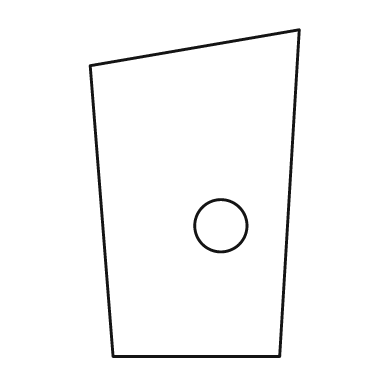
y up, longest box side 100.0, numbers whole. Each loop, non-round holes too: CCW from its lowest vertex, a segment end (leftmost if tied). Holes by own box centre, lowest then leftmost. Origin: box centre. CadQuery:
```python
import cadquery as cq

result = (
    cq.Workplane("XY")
    .moveTo(-25.0, -50.0)
    .lineTo(26.0, -50.0)
    .lineTo(32.0, 50.0)
    .lineTo(-32.0, 39.0)
    .close()
    .moveTo(8.0, -10.0)
    .circle(8.0)
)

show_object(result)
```